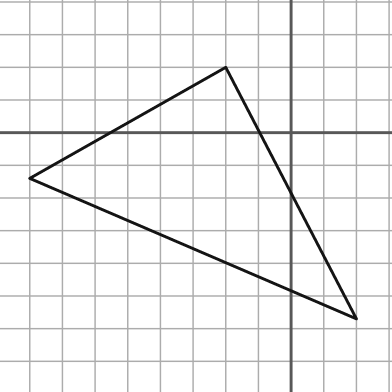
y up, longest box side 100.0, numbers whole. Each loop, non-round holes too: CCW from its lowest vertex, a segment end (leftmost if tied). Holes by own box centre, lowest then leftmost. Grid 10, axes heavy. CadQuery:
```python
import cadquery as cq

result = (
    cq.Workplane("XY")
    .moveTo(20.0, -57.0)
    .lineTo(-20.0, 20.0)
    .lineTo(-80.0, -14.0)
    .close()
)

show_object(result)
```